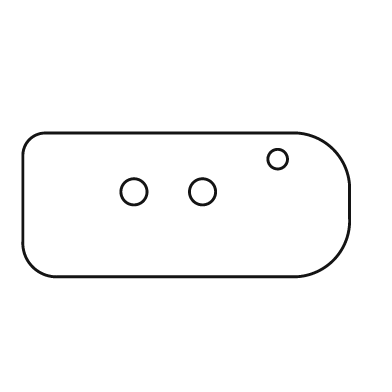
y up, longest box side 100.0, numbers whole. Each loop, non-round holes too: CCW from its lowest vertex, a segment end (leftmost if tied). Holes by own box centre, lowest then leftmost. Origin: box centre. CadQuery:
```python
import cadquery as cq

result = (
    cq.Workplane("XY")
    .moveTo(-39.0, -22.0)
    .lineTo(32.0, -22.0)
    .threePointArc((45.0, -17.0), (50.0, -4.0))
    .lineTo(50.0, 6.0)
    .threePointArc((45.0, 17.0), (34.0, 22.0))
    .lineTo(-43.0, 22.0)
    .threePointArc((-48.0, 20.0), (-50.0, 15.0))
    .lineTo(-50.0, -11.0)
    .threePointArc((-47.0, -19.0), (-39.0, -22.0))
    .close()
    .moveTo(-16.0, 4.0)
    .circle(4.0)
    .moveTo(5.0, 4.0)
    .circle(4.0)
    .moveTo(28.0, 14.0)
    .circle(3.0)
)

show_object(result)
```